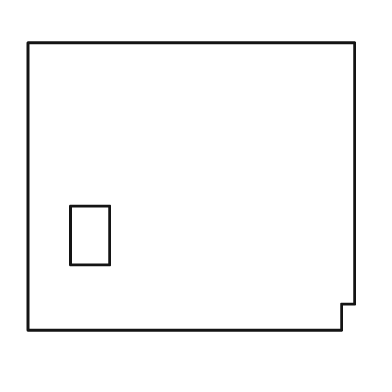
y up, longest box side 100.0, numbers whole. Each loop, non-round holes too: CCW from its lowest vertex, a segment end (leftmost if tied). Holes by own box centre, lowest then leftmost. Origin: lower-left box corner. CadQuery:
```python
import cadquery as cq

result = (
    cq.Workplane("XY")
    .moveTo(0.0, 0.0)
    .lineTo(96.0, 0.0)
    .lineTo(96.0, 8.0)
    .lineTo(100.0, 8.0)
    .lineTo(100.0, 88.0)
    .lineTo(0.0, 88.0)
    .close()
    .moveTo(13.0, 20.0)
    .lineTo(25.0, 20.0)
    .lineTo(25.0, 38.0)
    .lineTo(13.0, 38.0)
    .close()
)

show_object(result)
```